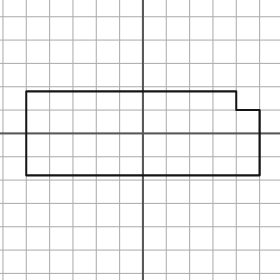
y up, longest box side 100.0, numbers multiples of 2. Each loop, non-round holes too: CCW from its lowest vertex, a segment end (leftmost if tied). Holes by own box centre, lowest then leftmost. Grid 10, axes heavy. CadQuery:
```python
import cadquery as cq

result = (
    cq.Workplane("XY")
    .moveTo(-50.0, -18.0)
    .lineTo(50.0, -18.0)
    .lineTo(50.0, 10.0)
    .lineTo(40.0, 10.0)
    .lineTo(40.0, 18.0)
    .lineTo(-50.0, 18.0)
    .close()
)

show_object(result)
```